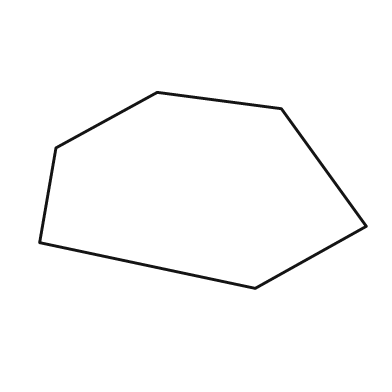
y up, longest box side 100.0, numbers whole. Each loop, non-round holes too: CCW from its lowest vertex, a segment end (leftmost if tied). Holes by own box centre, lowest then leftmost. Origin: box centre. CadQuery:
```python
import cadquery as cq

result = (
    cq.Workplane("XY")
    .moveTo(16.0, -30.0)
    .lineTo(50.0, -11.0)
    .lineTo(24.0, 25.0)
    .lineTo(-14.0, 30.0)
    .lineTo(-45.0, 13.0)
    .lineTo(-50.0, -16.0)
    .close()
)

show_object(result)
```